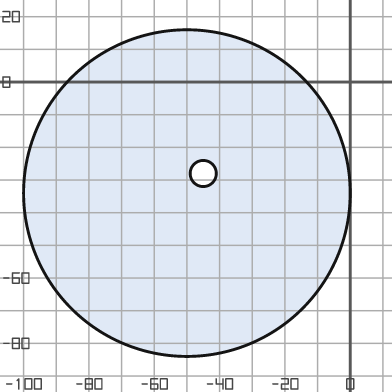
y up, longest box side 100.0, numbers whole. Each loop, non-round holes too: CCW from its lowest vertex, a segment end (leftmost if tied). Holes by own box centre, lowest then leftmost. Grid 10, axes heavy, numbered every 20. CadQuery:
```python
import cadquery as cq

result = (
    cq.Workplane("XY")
    .moveTo(-50.0, -34.0)
    .circle(50.0)
    .moveTo(-45.0, -28.0)
    .circle(4.0)
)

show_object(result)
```